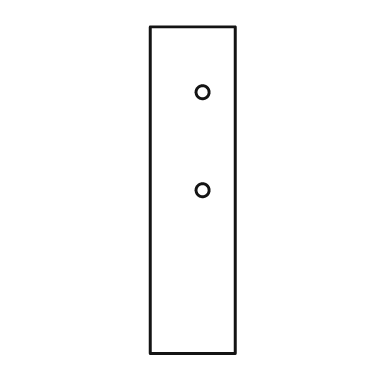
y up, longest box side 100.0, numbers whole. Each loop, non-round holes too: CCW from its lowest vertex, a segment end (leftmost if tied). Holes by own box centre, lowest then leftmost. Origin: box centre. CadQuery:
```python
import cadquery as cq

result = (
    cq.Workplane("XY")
    .moveTo(-13.0, -50.0)
    .lineTo(13.0, -50.0)
    .lineTo(13.0, 50.0)
    .lineTo(-13.0, 50.0)
    .close()
    .moveTo(3.0, 0.0)
    .circle(2.0)
    .moveTo(3.0, 30.0)
    .circle(2.0)
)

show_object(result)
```